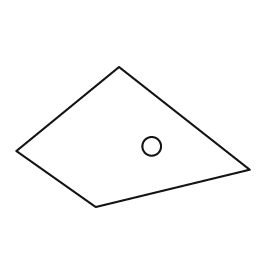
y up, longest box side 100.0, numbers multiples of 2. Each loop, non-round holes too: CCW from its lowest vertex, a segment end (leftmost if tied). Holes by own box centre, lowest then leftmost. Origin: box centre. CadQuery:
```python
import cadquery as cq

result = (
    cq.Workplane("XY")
    .moveTo(-16.0, -30.0)
    .lineTo(50.0, -14.0)
    .lineTo(-6.0, 30.0)
    .lineTo(-50.0, -6.0)
    .close()
    .moveTo(8.0, -4.0)
    .circle(4.0)
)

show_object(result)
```